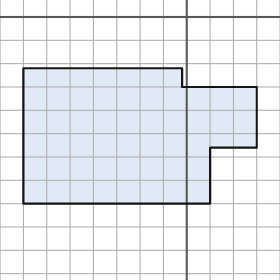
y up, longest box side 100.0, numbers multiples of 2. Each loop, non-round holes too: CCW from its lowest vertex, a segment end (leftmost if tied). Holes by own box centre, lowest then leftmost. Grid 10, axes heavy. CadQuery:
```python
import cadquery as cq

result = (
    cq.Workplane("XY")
    .moveTo(-70.0, -80.0)
    .lineTo(10.0, -80.0)
    .lineTo(10.0, -56.0)
    .lineTo(30.0, -56.0)
    .lineTo(30.0, -30.0)
    .lineTo(-2.0, -30.0)
    .lineTo(-2.0, -22.0)
    .lineTo(-70.0, -22.0)
    .close()
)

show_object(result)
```